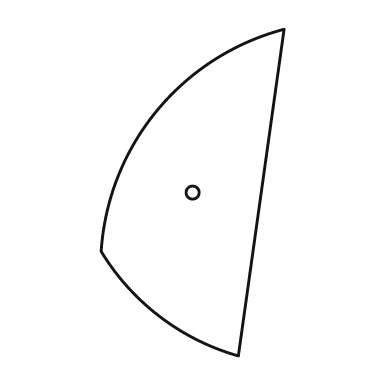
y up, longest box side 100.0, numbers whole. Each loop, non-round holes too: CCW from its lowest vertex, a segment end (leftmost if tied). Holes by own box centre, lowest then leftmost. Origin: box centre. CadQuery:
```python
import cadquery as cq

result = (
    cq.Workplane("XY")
    .moveTo(14.0, -50.0)
    .lineTo(28.0, 50.0)
    .threePointArc((-11.0, 25.0), (-28.0, -18.0))
    .threePointArc((-10.0, -38.0), (14.0, -50.0))
    .close()
    .moveTo(0.0, 0.0)
    .circle(2.0)
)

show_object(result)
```